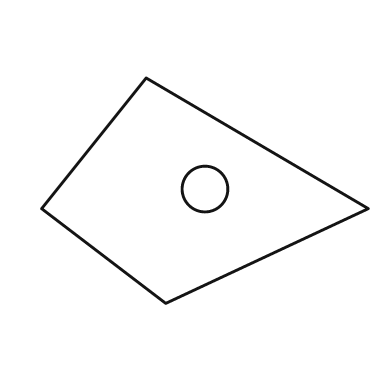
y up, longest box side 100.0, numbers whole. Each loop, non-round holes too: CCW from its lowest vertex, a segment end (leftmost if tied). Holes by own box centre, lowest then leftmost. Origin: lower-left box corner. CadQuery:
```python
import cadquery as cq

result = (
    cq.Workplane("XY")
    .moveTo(38.0, 0.0)
    .lineTo(100.0, 29.0)
    .lineTo(32.0, 69.0)
    .lineTo(0.0, 29.0)
    .close()
    .moveTo(50.0, 35.0)
    .circle(7.0)
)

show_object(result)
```